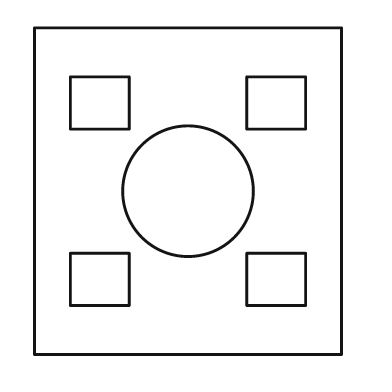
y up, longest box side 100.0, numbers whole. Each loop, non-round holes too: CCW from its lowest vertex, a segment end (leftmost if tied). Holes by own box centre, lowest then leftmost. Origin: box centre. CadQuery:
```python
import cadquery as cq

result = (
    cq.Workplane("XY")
    .moveTo(-47.0, -50.0)
    .lineTo(47.0, -50.0)
    .lineTo(47.0, 50.0)
    .lineTo(-47.0, 50.0)
    .close()
    .moveTo(-36.0, -35.0)
    .lineTo(-18.0, -35.0)
    .lineTo(-18.0, -19.0)
    .lineTo(-36.0, -19.0)
    .close()
    .moveTo(18.0, -35.0)
    .lineTo(36.0, -35.0)
    .lineTo(36.0, -19.0)
    .lineTo(18.0, -19.0)
    .close()
    .moveTo(0.0, 0.0)
    .circle(20.0)
    .moveTo(-36.0, 19.0)
    .lineTo(-18.0, 19.0)
    .lineTo(-18.0, 35.0)
    .lineTo(-36.0, 35.0)
    .close()
    .moveTo(18.0, 19.0)
    .lineTo(36.0, 19.0)
    .lineTo(36.0, 35.0)
    .lineTo(18.0, 35.0)
    .close()
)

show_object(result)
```